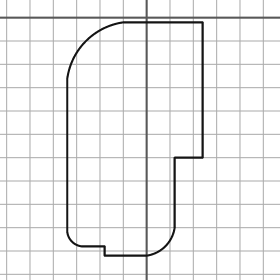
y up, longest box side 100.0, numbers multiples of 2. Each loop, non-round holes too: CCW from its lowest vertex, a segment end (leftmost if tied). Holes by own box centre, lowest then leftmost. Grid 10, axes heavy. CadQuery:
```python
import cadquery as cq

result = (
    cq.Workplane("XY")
    .moveTo(-18.0, -102.0)
    .lineTo(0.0, -102.0)
    .threePointArc((8.0, -98.0), (12.0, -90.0))
    .lineTo(12.0, -60.0)
    .lineTo(24.0, -60.0)
    .lineTo(24.0, -2.0)
    .lineTo(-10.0, -2.0)
    .threePointArc((-26.0, -10.0), (-34.0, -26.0))
    .lineTo(-34.0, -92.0)
    .threePointArc((-32.0, -96.0), (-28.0, -98.0))
    .lineTo(-18.0, -98.0)
    .close()
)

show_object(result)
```